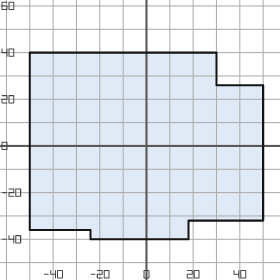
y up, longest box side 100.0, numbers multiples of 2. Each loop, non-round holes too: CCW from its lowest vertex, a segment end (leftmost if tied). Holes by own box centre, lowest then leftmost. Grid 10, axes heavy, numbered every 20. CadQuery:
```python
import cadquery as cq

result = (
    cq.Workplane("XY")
    .moveTo(-24.0, -40.0)
    .lineTo(18.0, -40.0)
    .lineTo(18.0, -32.0)
    .lineTo(50.0, -32.0)
    .lineTo(50.0, 26.0)
    .lineTo(30.0, 26.0)
    .lineTo(30.0, 40.0)
    .lineTo(-50.0, 40.0)
    .lineTo(-50.0, -36.0)
    .lineTo(-24.0, -36.0)
    .close()
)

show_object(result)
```